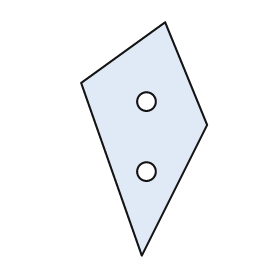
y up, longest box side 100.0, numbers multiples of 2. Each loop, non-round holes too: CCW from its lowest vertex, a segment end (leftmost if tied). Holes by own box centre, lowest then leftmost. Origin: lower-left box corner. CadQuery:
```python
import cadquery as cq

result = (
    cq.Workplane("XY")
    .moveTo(26.0, 0.0)
    .lineTo(54.0, 56.0)
    .lineTo(36.0, 100.0)
    .lineTo(0.0, 74.0)
    .close()
    .moveTo(28.0, 36.0)
    .circle(4.0)
    .moveTo(28.0, 66.0)
    .circle(4.0)
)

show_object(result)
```